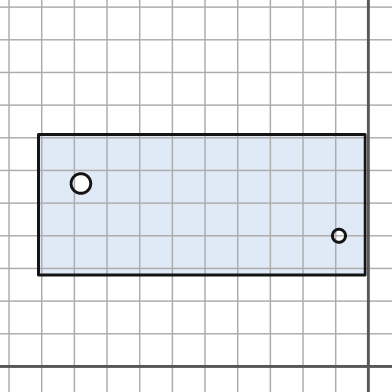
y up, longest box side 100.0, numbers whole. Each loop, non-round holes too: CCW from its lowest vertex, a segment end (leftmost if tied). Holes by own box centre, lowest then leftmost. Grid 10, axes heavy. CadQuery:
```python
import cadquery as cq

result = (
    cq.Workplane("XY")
    .moveTo(-101.0, 28.0)
    .lineTo(-1.0, 28.0)
    .lineTo(-1.0, 71.0)
    .lineTo(-101.0, 71.0)
    .close()
    .moveTo(-9.0, 40.0)
    .circle(2.0)
    .moveTo(-88.0, 56.0)
    .circle(3.0)
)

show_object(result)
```